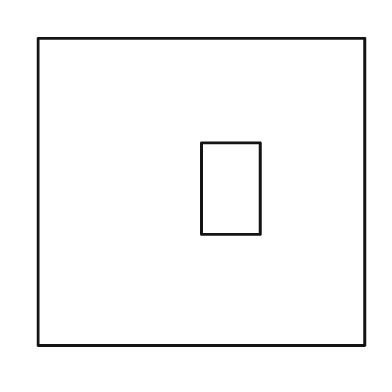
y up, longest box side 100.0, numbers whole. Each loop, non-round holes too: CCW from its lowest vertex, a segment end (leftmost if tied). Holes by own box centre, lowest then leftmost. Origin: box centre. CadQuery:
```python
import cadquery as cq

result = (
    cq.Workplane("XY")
    .moveTo(-50.0, -47.0)
    .lineTo(50.0, -47.0)
    .lineTo(50.0, 47.0)
    .lineTo(-50.0, 47.0)
    .close()
    .moveTo(0.0, -13.0)
    .lineTo(18.0, -13.0)
    .lineTo(18.0, 15.0)
    .lineTo(0.0, 15.0)
    .close()
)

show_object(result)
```